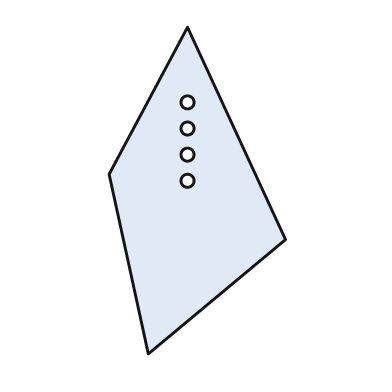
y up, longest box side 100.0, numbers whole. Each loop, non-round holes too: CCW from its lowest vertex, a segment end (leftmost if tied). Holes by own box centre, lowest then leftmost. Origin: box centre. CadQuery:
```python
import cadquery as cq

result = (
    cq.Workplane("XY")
    .moveTo(-15.0, -50.0)
    .lineTo(27.0, -15.0)
    .lineTo(-3.0, 50.0)
    .lineTo(-27.0, 5.0)
    .close()
    .moveTo(-3.0, 3.0)
    .circle(2.0)
    .moveTo(-3.0, 11.0)
    .circle(2.0)
    .moveTo(-3.0, 19.0)
    .circle(2.0)
    .moveTo(-3.0, 27.0)
    .circle(2.0)
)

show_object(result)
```